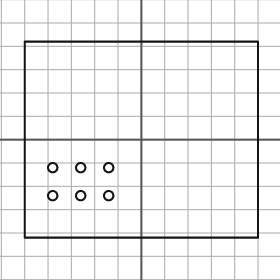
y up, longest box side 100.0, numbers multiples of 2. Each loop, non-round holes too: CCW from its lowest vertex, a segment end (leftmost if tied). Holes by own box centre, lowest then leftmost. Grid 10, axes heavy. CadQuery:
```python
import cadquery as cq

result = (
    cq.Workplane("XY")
    .moveTo(-50.0, -42.0)
    .lineTo(50.0, -42.0)
    .lineTo(50.0, 42.0)
    .lineTo(-50.0, 42.0)
    .close()
    .moveTo(-38.0, -24.0)
    .circle(2.0)
    .moveTo(-26.0, -24.0)
    .circle(2.0)
    .moveTo(-14.0, -24.0)
    .circle(2.0)
    .moveTo(-38.0, -12.0)
    .circle(2.0)
    .moveTo(-26.0, -12.0)
    .circle(2.0)
    .moveTo(-14.0, -12.0)
    .circle(2.0)
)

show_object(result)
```